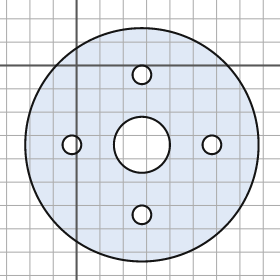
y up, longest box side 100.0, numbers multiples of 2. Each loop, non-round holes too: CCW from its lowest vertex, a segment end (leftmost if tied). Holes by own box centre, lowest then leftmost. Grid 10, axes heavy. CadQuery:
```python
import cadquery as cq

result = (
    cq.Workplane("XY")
    .moveTo(28.0, -34.0)
    .circle(50.0)
    .moveTo(28.0, -64.0)
    .circle(4.0)
    .moveTo(-2.0, -34.0)
    .circle(4.0)
    .moveTo(28.0, -34.0)
    .circle(12.0)
    .moveTo(58.0, -34.0)
    .circle(4.0)
    .moveTo(28.0, -4.0)
    .circle(4.0)
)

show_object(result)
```